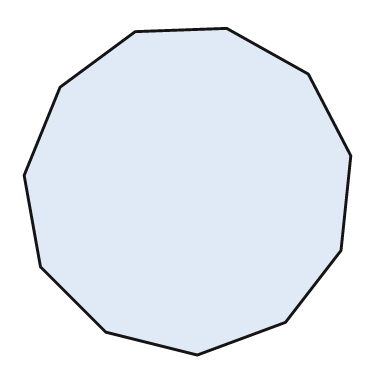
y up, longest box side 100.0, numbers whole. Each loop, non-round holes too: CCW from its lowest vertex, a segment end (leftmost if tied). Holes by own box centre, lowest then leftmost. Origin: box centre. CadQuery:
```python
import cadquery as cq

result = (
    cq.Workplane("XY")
    .moveTo(3.0, -50.0)
    .lineTo(30.0, -40.0)
    .lineTo(47.0, -18.0)
    .lineTo(50.0, 11.0)
    .lineTo(37.0, 36.0)
    .lineTo(12.0, 50.0)
    .lineTo(-16.0, 49.0)
    .lineTo(-39.0, 32.0)
    .lineTo(-50.0, 5.0)
    .lineTo(-45.0, -23.0)
    .lineTo(-25.0, -43.0)
    .close()
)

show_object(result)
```